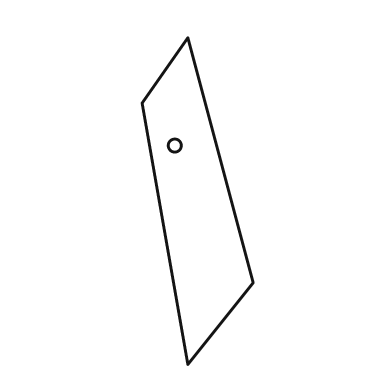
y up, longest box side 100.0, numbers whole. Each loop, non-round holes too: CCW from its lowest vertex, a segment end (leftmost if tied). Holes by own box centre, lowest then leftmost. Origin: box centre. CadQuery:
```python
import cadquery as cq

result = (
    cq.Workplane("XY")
    .moveTo(-3.0, -50.0)
    .lineTo(17.0, -25.0)
    .lineTo(-3.0, 50.0)
    .lineTo(-17.0, 30.0)
    .close()
    .moveTo(-7.0, 17.0)
    .circle(2.0)
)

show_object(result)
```